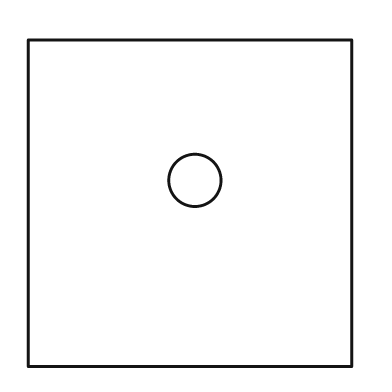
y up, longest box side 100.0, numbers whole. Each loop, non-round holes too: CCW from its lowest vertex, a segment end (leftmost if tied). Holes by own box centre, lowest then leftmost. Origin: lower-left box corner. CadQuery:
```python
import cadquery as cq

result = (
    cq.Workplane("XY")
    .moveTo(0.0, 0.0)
    .lineTo(99.0, 0.0)
    .lineTo(99.0, 100.0)
    .lineTo(0.0, 100.0)
    .close()
    .moveTo(51.0, 57.0)
    .circle(8.0)
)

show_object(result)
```